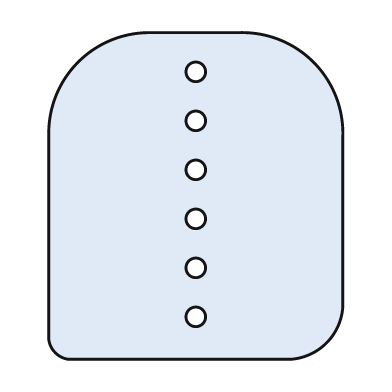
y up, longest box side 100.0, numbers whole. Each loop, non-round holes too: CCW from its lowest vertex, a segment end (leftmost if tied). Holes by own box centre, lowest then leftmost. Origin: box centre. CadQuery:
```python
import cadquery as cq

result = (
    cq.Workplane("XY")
    .moveTo(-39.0, -50.0)
    .lineTo(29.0, -50.0)
    .threePointArc((40.0, -45.0), (45.0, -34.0))
    .lineTo(45.0, 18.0)
    .threePointArc((36.0, 41.0), (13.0, 50.0))
    .lineTo(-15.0, 50.0)
    .threePointArc((-36.0, 41.0), (-45.0, 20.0))
    .lineTo(-45.0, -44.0)
    .threePointArc((-43.0, -48.0), (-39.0, -50.0))
    .close()
    .moveTo(0.0, -37.0)
    .circle(3.0)
    .moveTo(0.0, -22.0)
    .circle(3.0)
    .moveTo(0.0, -7.0)
    .circle(3.0)
    .moveTo(0.0, 8.0)
    .circle(3.0)
    .moveTo(0.0, 23.0)
    .circle(3.0)
    .moveTo(0.0, 38.0)
    .circle(3.0)
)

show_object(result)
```